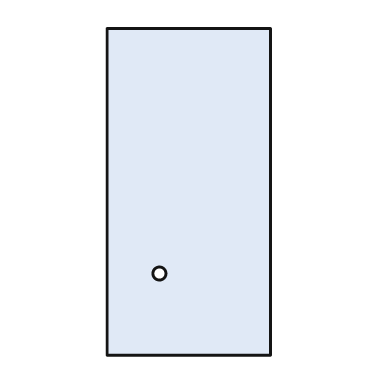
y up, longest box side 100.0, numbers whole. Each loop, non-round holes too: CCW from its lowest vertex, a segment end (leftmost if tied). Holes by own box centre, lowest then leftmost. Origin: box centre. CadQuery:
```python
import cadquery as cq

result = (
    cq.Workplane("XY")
    .moveTo(-25.0, -50.0)
    .lineTo(25.0, -50.0)
    .lineTo(25.0, 50.0)
    .lineTo(-25.0, 50.0)
    .close()
    .moveTo(-9.0, -25.0)
    .circle(2.0)
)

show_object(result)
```